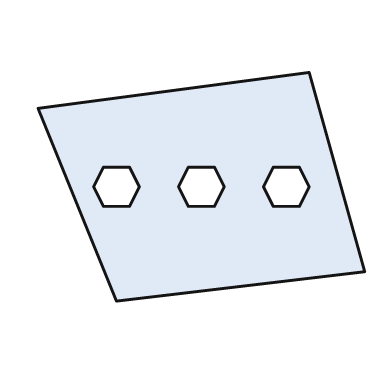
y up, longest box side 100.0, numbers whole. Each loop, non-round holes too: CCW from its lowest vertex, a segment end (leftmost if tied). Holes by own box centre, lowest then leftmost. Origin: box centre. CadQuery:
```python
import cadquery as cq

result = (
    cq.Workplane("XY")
    .moveTo(-26.0, -35.0)
    .lineTo(50.0, -26.0)
    .lineTo(33.0, 35.0)
    .lineTo(-50.0, 24.0)
    .close()
    .moveTo(-30.0, -6.0)
    .lineTo(-22.0, -6.0)
    .lineTo(-19.0, 0.0)
    .lineTo(-22.0, 6.0)
    .lineTo(-30.0, 6.0)
    .lineTo(-33.0, 0.0)
    .close()
    .moveTo(-4.0, -6.0)
    .lineTo(4.0, -6.0)
    .lineTo(7.0, 0.0)
    .lineTo(4.0, 6.0)
    .lineTo(-4.0, 6.0)
    .lineTo(-7.0, 0.0)
    .close()
    .moveTo(22.0, -6.0)
    .lineTo(30.0, -6.0)
    .lineTo(33.0, 0.0)
    .lineTo(30.0, 6.0)
    .lineTo(22.0, 6.0)
    .lineTo(19.0, 0.0)
    .close()
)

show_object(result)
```